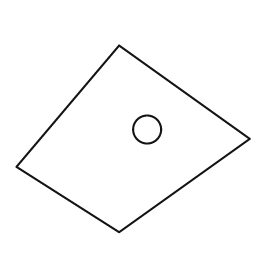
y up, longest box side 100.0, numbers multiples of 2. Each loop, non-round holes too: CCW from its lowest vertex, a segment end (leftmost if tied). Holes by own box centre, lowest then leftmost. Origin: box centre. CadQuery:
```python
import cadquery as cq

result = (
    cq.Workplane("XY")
    .moveTo(-6.0, -40.0)
    .lineTo(50.0, 0.0)
    .lineTo(-6.0, 40.0)
    .lineTo(-50.0, -12.0)
    .close()
    .moveTo(6.0, 4.0)
    .circle(6.0)
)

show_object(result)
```